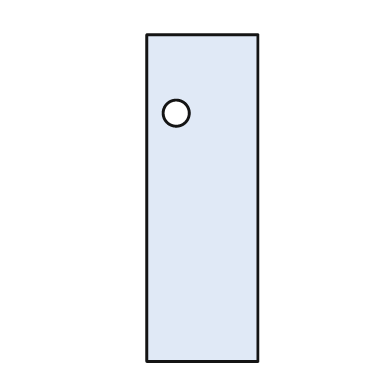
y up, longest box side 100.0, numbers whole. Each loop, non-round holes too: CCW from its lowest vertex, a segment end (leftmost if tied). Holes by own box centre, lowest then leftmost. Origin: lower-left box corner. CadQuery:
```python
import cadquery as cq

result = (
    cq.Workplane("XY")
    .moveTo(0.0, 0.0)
    .lineTo(34.0, 0.0)
    .lineTo(34.0, 100.0)
    .lineTo(0.0, 100.0)
    .close()
    .moveTo(9.0, 76.0)
    .circle(4.0)
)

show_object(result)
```